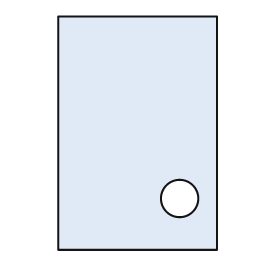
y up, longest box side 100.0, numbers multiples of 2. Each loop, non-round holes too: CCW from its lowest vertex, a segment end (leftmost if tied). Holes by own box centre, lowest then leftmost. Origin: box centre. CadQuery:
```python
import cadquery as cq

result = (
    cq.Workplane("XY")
    .moveTo(-34.0, -50.0)
    .lineTo(34.0, -50.0)
    .lineTo(34.0, 50.0)
    .lineTo(-34.0, 50.0)
    .close()
    .moveTo(18.0, -28.0)
    .circle(8.0)
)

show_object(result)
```